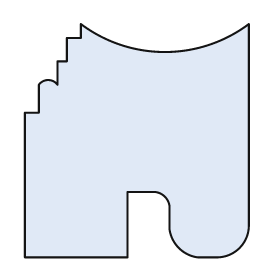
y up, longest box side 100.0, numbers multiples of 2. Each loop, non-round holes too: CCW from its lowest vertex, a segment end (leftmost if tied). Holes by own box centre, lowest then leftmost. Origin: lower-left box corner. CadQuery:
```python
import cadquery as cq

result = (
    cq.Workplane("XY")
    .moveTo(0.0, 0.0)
    .lineTo(44.0, 0.0)
    .lineTo(44.0, 28.0)
    .lineTo(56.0, 28.0)
    .threePointArc((60.0, 26.0), (62.0, 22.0))
    .lineTo(62.0, 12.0)
    .threePointArc((66.0, 4.0), (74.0, 0.0))
    .lineTo(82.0, 0.0)
    .threePointArc((92.0, 4.0), (96.0, 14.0))
    .lineTo(96.0, 100.0)
    .threePointArc((60.0, 88.0), (24.0, 100.0))
    .lineTo(24.0, 94.0)
    .lineTo(18.0, 94.0)
    .lineTo(18.0, 84.0)
    .lineTo(14.0, 84.0)
    .lineTo(14.0, 74.0)
    .threePointArc((10.0, 76.0), (6.0, 74.0))
    .lineTo(6.0, 62.0)
    .lineTo(0.0, 62.0)
    .close()
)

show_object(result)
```